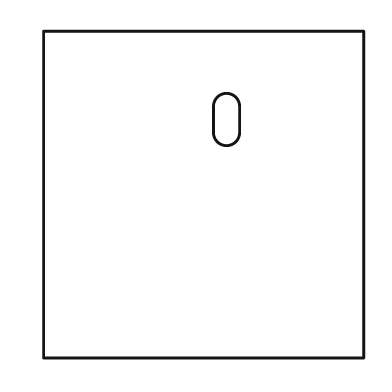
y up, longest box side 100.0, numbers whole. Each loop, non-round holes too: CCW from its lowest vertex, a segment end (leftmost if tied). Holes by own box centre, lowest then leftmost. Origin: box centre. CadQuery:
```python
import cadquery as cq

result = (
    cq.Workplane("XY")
    .moveTo(-49.0, -50.0)
    .lineTo(49.0, -50.0)
    .lineTo(49.0, 50.0)
    .lineTo(-49.0, 50.0)
    .close()
    .moveTo(3.0, 19.0)
    .threePointArc((7.0, 15.0), (11.0, 19.0))
    .lineTo(11.0, 27.0)
    .threePointArc((7.0, 31.0), (3.0, 27.0))
    .close()
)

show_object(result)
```